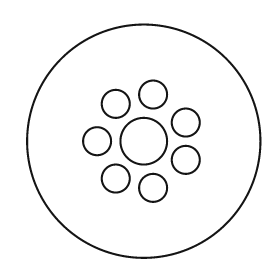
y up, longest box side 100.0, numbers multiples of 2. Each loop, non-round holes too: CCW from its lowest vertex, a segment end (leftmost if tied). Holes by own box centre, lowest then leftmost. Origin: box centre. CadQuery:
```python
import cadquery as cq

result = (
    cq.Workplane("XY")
    .moveTo(0.0, 0.0)
    .circle(50.0)
    .moveTo(4.0, -20.0)
    .circle(6.0)
    .moveTo(-12.0, -16.0)
    .circle(6.0)
    .moveTo(18.0, -8.0)
    .circle(6.0)
    .moveTo(-20.0, 0.0)
    .circle(6.0)
    .moveTo(0.0, 0.0)
    .circle(10.0)
    .moveTo(18.0, 8.0)
    .circle(6.0)
    .moveTo(-12.0, 16.0)
    .circle(6.0)
    .moveTo(4.0, 20.0)
    .circle(6.0)
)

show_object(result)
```